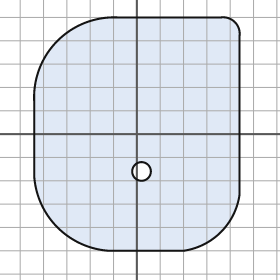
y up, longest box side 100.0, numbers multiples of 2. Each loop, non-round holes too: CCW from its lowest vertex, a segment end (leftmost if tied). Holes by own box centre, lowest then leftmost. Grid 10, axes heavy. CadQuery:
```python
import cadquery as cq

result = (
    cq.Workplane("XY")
    .moveTo(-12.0, -50.0)
    .lineTo(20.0, -50.0)
    .threePointArc((36.0, -42.0), (44.0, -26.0))
    .lineTo(44.0, 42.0)
    .threePointArc((42.0, 48.0), (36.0, 50.0))
    .lineTo(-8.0, 50.0)
    .threePointArc((-34.0, 40.0), (-44.0, 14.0))
    .lineTo(-44.0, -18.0)
    .threePointArc((-34.0, -40.0), (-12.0, -50.0))
    .close()
    .moveTo(2.0, -16.0)
    .circle(4.0)
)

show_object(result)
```